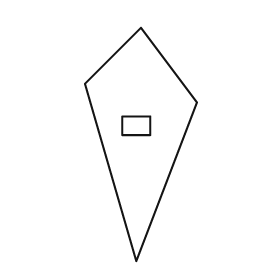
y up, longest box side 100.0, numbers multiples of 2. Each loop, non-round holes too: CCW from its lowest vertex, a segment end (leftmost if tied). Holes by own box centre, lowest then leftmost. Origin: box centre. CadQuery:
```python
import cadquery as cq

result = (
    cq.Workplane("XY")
    .moveTo(-2.0, -50.0)
    .lineTo(24.0, 18.0)
    .lineTo(0.0, 50.0)
    .lineTo(-24.0, 26.0)
    .close()
    .moveTo(-8.0, 4.0)
    .lineTo(4.0, 4.0)
    .lineTo(4.0, 12.0)
    .lineTo(-8.0, 12.0)
    .close()
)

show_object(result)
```